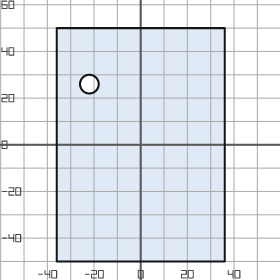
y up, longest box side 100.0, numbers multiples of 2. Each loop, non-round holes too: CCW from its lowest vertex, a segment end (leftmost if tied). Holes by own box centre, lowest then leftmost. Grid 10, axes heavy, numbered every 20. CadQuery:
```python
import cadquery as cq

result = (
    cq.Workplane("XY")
    .moveTo(-36.0, -50.0)
    .lineTo(36.0, -50.0)
    .lineTo(36.0, 50.0)
    .lineTo(-36.0, 50.0)
    .close()
    .moveTo(-22.0, 26.0)
    .circle(4.0)
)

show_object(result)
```